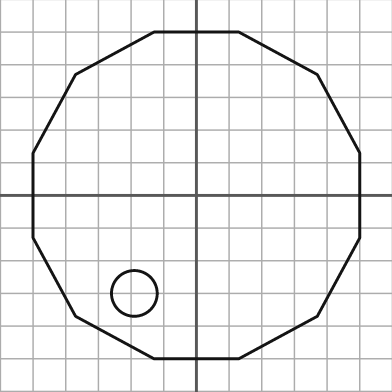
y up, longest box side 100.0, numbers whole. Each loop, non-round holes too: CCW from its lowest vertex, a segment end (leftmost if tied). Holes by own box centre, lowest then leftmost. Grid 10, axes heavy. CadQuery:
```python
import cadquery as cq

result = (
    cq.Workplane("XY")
    .moveTo(-13.0, -50.0)
    .lineTo(13.0, -50.0)
    .lineTo(37.0, -37.0)
    .lineTo(50.0, -13.0)
    .lineTo(50.0, 13.0)
    .lineTo(37.0, 37.0)
    .lineTo(13.0, 50.0)
    .lineTo(-13.0, 50.0)
    .lineTo(-37.0, 37.0)
    .lineTo(-50.0, 13.0)
    .lineTo(-50.0, -13.0)
    .lineTo(-37.0, -37.0)
    .close()
    .moveTo(-19.0, -30.0)
    .circle(7.0)
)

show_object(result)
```